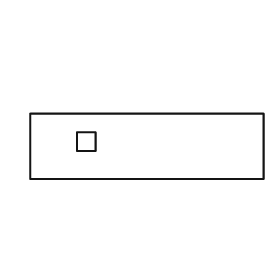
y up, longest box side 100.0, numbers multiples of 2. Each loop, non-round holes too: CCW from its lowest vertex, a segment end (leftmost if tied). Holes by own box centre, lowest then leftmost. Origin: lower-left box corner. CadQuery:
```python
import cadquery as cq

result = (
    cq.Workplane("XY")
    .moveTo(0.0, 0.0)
    .lineTo(100.0, 0.0)
    .lineTo(100.0, 28.0)
    .lineTo(0.0, 28.0)
    .close()
    .moveTo(20.0, 12.0)
    .lineTo(28.0, 12.0)
    .lineTo(28.0, 20.0)
    .lineTo(20.0, 20.0)
    .close()
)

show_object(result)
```